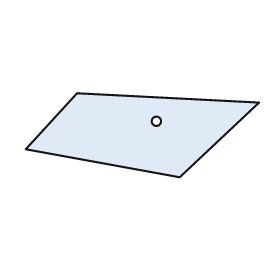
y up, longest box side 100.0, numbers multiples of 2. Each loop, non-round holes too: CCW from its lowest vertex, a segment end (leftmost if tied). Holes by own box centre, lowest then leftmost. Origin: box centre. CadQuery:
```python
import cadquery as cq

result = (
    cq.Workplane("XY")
    .moveTo(16.0, -18.0)
    .lineTo(50.0, 14.0)
    .lineTo(-28.0, 18.0)
    .lineTo(-50.0, -6.0)
    .close()
    .moveTo(6.0, 6.0)
    .circle(2.0)
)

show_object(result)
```